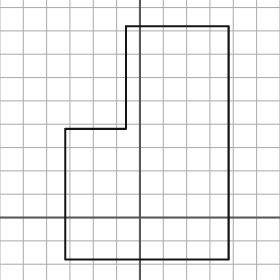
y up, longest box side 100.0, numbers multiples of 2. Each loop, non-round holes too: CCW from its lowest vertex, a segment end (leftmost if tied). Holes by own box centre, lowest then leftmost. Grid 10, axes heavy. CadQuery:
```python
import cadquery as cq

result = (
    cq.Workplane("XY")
    .moveTo(-32.0, -18.0)
    .lineTo(38.0, -18.0)
    .lineTo(38.0, 82.0)
    .lineTo(-6.0, 82.0)
    .lineTo(-6.0, 38.0)
    .lineTo(-32.0, 38.0)
    .close()
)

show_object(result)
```